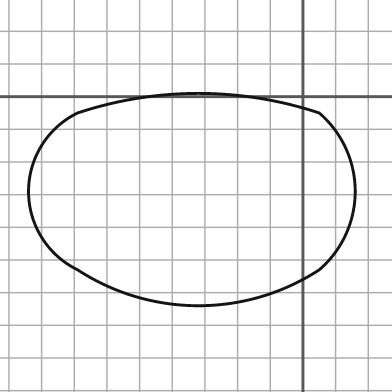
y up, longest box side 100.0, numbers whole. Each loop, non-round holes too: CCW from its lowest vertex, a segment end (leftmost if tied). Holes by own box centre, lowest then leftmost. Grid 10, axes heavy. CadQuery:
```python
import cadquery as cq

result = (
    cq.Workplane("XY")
    .moveTo(-69.0, -53.0)
    .threePointArc((-32.0, -64.0), (5.0, -53.0))
    .threePointArc((16.0, -29.0), (5.0, -5.0))
    .threePointArc((-32.0, 1.0), (-69.0, -5.0))
    .threePointArc((-84.0, -29.0), (-69.0, -53.0))
    .close()
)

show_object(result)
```